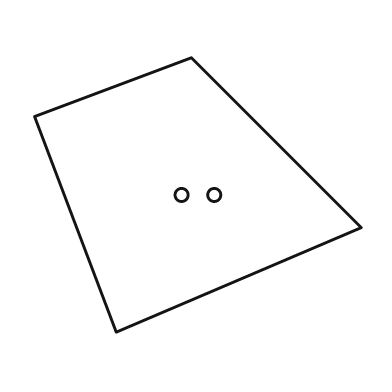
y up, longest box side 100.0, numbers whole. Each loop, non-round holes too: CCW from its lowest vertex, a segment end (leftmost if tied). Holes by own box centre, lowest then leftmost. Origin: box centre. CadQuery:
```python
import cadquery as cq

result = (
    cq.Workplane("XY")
    .moveTo(-25.0, -42.0)
    .lineTo(50.0, -10.0)
    .lineTo(-2.0, 42.0)
    .lineTo(-50.0, 24.0)
    .close()
    .moveTo(-5.0, 0.0)
    .circle(2.0)
    .moveTo(5.0, 0.0)
    .circle(2.0)
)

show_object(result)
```